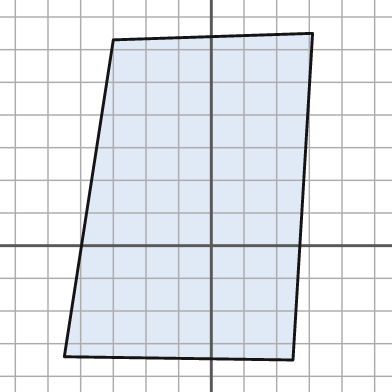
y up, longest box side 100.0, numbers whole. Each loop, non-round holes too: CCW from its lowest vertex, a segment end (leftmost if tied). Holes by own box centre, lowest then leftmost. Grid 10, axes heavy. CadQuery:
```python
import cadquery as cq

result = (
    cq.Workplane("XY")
    .moveTo(25.0, -35.0)
    .lineTo(31.0, 65.0)
    .lineTo(-30.0, 63.0)
    .lineTo(-45.0, -34.0)
    .close()
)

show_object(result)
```